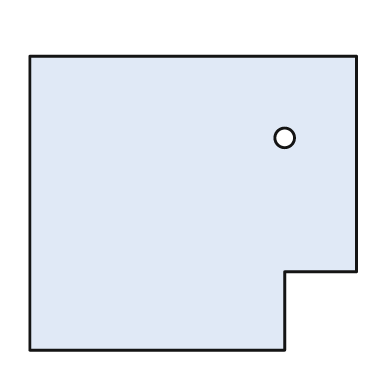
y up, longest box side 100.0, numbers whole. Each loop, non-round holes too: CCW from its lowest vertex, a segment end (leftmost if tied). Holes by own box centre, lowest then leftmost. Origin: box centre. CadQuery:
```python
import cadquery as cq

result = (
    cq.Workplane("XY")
    .moveTo(-50.0, -45.0)
    .lineTo(28.0, -45.0)
    .lineTo(28.0, -21.0)
    .lineTo(50.0, -21.0)
    .lineTo(50.0, 45.0)
    .lineTo(-50.0, 45.0)
    .close()
    .moveTo(28.0, 20.0)
    .circle(3.0)
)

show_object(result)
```